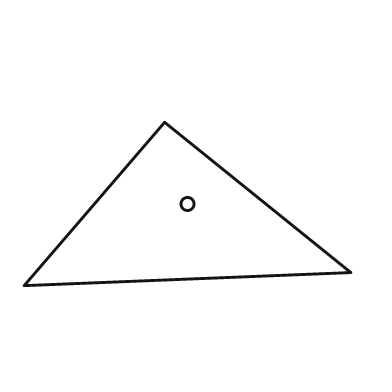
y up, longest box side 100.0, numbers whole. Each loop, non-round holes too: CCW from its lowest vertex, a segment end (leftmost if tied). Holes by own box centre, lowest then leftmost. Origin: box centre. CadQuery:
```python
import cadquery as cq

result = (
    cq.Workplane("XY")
    .moveTo(-50.0, -25.0)
    .lineTo(50.0, -21.0)
    .lineTo(-7.0, 25.0)
    .close()
    .moveTo(0.0, 0.0)
    .circle(2.0)
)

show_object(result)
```